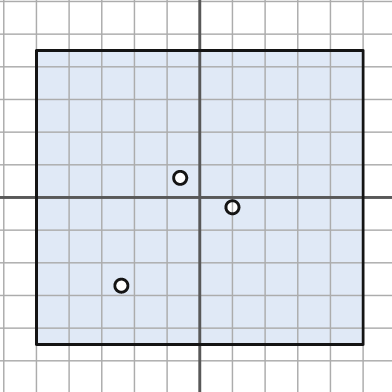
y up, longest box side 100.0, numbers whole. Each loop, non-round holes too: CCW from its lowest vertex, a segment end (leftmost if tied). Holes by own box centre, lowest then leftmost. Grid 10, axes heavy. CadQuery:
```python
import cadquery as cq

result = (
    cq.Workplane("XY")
    .moveTo(-50.0, -45.0)
    .lineTo(50.0, -45.0)
    .lineTo(50.0, 45.0)
    .lineTo(-50.0, 45.0)
    .close()
    .moveTo(-24.0, -27.0)
    .circle(2.0)
    .moveTo(10.0, -3.0)
    .circle(2.0)
    .moveTo(-6.0, 6.0)
    .circle(2.0)
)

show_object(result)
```